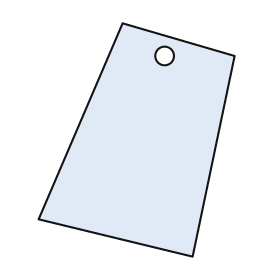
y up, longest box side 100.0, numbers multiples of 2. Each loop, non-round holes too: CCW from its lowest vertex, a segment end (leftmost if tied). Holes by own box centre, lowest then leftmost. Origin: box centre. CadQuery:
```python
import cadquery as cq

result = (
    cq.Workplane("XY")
    .moveTo(24.0, -50.0)
    .lineTo(42.0, 36.0)
    .lineTo(-6.0, 50.0)
    .lineTo(-42.0, -34.0)
    .close()
    .moveTo(12.0, 36.0)
    .circle(4.0)
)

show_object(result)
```